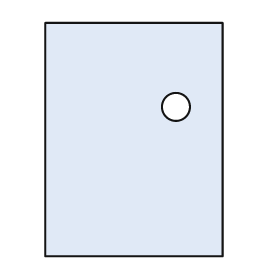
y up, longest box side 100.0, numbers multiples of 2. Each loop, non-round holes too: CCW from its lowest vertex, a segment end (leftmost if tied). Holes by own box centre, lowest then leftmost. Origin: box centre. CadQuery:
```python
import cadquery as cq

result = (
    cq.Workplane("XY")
    .moveTo(-38.0, -50.0)
    .lineTo(38.0, -50.0)
    .lineTo(38.0, 50.0)
    .lineTo(-38.0, 50.0)
    .close()
    .moveTo(18.0, 14.0)
    .circle(6.0)
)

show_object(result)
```